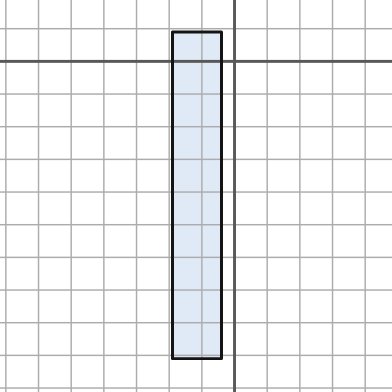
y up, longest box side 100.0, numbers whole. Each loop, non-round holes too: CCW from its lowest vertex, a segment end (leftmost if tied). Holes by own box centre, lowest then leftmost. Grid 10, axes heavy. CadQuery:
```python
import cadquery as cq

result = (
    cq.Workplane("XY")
    .moveTo(-19.0, -91.0)
    .lineTo(-4.0, -91.0)
    .lineTo(-4.0, 9.0)
    .lineTo(-19.0, 9.0)
    .close()
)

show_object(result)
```